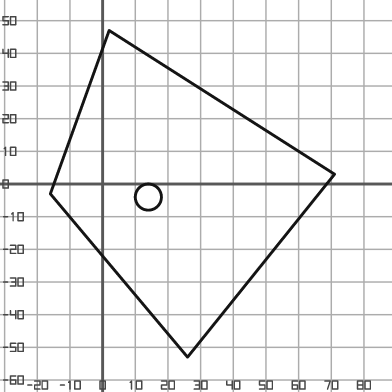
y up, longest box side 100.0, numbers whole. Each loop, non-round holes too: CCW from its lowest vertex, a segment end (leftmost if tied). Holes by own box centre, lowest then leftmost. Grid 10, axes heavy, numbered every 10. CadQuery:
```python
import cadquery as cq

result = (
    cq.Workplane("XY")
    .moveTo(26.0, -53.0)
    .lineTo(71.0, 3.0)
    .lineTo(2.0, 47.0)
    .lineTo(-16.0, -3.0)
    .close()
    .moveTo(14.0, -4.0)
    .circle(4.0)
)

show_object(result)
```